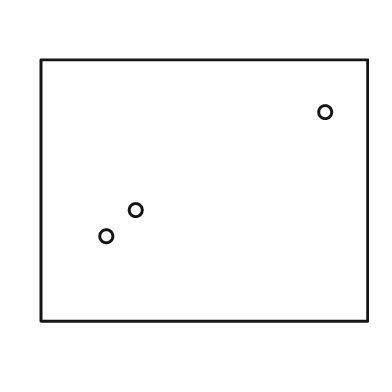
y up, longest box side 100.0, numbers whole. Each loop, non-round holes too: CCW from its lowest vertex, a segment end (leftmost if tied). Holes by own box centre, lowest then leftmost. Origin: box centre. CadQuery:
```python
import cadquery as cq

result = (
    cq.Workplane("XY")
    .moveTo(-50.0, -40.0)
    .lineTo(50.0, -40.0)
    .lineTo(50.0, 40.0)
    .lineTo(-50.0, 40.0)
    .close()
    .moveTo(-30.0, -14.0)
    .circle(2.0)
    .moveTo(-21.0, -6.0)
    .circle(2.0)
    .moveTo(37.0, 24.0)
    .circle(2.0)
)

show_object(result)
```